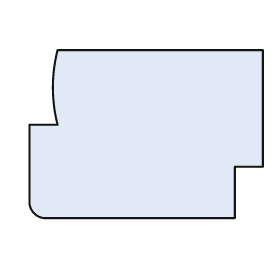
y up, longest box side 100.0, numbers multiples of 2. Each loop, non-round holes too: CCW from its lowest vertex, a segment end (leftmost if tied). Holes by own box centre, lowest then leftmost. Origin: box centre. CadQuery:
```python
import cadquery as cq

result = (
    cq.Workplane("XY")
    .moveTo(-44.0, -36.0)
    .lineTo(38.0, -36.0)
    .lineTo(38.0, -14.0)
    .lineTo(50.0, -14.0)
    .lineTo(50.0, 36.0)
    .lineTo(-38.0, 36.0)
    .threePointArc((-40.0, 20.0), (-38.0, 4.0))
    .lineTo(-50.0, 4.0)
    .lineTo(-50.0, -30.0)
    .threePointArc((-48.0, -34.0), (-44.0, -36.0))
    .close()
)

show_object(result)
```